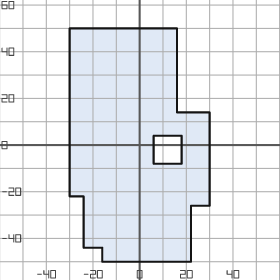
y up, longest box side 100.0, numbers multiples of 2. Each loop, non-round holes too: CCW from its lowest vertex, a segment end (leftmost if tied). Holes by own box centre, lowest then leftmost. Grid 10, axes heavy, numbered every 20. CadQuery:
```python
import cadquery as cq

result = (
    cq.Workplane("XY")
    .moveTo(-16.0, -50.0)
    .lineTo(22.0, -50.0)
    .lineTo(22.0, -26.0)
    .lineTo(30.0, -26.0)
    .lineTo(30.0, 14.0)
    .lineTo(16.0, 14.0)
    .lineTo(16.0, 50.0)
    .lineTo(-30.0, 50.0)
    .lineTo(-30.0, -22.0)
    .lineTo(-24.0, -22.0)
    .lineTo(-24.0, -44.0)
    .lineTo(-16.0, -44.0)
    .close()
    .moveTo(6.0, -8.0)
    .lineTo(18.0, -8.0)
    .lineTo(18.0, 4.0)
    .lineTo(6.0, 4.0)
    .close()
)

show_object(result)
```